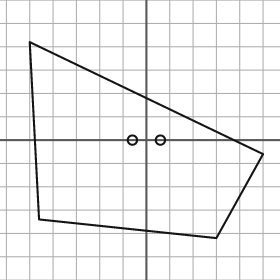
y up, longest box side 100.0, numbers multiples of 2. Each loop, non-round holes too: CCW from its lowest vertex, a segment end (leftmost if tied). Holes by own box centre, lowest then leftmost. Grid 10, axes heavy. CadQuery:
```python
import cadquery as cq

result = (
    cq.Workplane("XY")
    .moveTo(30.0, -42.0)
    .lineTo(50.0, -6.0)
    .lineTo(-50.0, 42.0)
    .lineTo(-46.0, -34.0)
    .close()
    .moveTo(-6.0, 0.0)
    .circle(2.0)
    .moveTo(6.0, 0.0)
    .circle(2.0)
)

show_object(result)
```